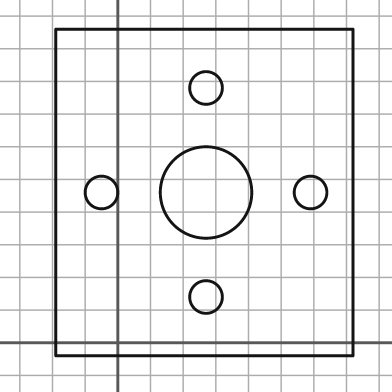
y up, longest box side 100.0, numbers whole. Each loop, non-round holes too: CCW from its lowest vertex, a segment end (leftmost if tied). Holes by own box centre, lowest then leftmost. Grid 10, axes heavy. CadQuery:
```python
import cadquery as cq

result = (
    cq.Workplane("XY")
    .moveTo(-19.0, -4.0)
    .lineTo(72.0, -4.0)
    .lineTo(72.0, 96.0)
    .lineTo(-19.0, 96.0)
    .close()
    .moveTo(27.0, 14.0)
    .circle(5.0)
    .moveTo(-5.0, 46.0)
    .circle(5.0)
    .moveTo(27.0, 46.0)
    .circle(14.0)
    .moveTo(59.0, 46.0)
    .circle(5.0)
    .moveTo(27.0, 78.0)
    .circle(5.0)
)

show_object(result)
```